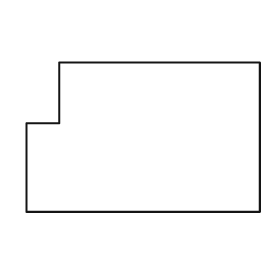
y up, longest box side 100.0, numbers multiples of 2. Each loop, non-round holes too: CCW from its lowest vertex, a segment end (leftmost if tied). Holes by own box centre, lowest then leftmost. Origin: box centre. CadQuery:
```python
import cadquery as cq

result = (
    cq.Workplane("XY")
    .moveTo(-50.0, -32.0)
    .lineTo(50.0, -32.0)
    .lineTo(50.0, 32.0)
    .lineTo(-36.0, 32.0)
    .lineTo(-36.0, 6.0)
    .lineTo(-50.0, 6.0)
    .close()
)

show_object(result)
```